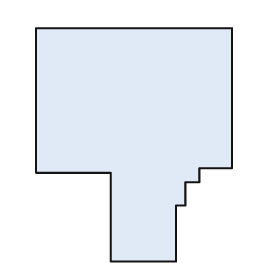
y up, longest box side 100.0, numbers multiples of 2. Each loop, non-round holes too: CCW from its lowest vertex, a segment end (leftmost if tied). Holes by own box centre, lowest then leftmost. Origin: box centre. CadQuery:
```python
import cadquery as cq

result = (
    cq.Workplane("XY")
    .moveTo(-10.0, -50.0)
    .lineTo(18.0, -50.0)
    .lineTo(18.0, -26.0)
    .lineTo(22.0, -26.0)
    .lineTo(22.0, -16.0)
    .lineTo(28.0, -16.0)
    .lineTo(28.0, -10.0)
    .lineTo(42.0, -10.0)
    .lineTo(42.0, 50.0)
    .lineTo(-42.0, 50.0)
    .lineTo(-42.0, -12.0)
    .lineTo(-10.0, -12.0)
    .close()
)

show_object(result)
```